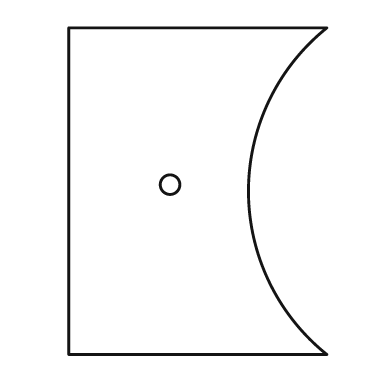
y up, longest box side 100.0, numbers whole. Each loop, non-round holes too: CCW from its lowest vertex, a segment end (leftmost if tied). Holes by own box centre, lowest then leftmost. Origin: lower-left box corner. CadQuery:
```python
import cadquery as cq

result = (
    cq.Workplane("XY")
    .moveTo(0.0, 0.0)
    .lineTo(79.0, 0.0)
    .threePointArc((55.0, 50.0), (79.0, 100.0))
    .lineTo(0.0, 100.0)
    .close()
    .moveTo(31.0, 52.0)
    .circle(3.0)
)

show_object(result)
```